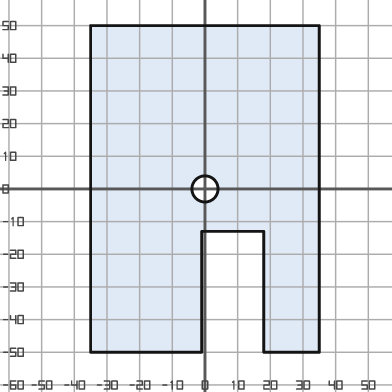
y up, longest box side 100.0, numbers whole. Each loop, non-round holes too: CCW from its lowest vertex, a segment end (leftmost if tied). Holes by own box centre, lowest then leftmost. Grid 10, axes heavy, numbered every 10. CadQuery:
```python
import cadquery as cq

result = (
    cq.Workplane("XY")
    .moveTo(-35.0, -50.0)
    .lineTo(-1.0, -50.0)
    .lineTo(-1.0, -13.0)
    .lineTo(18.0, -13.0)
    .lineTo(18.0, -50.0)
    .lineTo(35.0, -50.0)
    .lineTo(35.0, 50.0)
    .lineTo(-35.0, 50.0)
    .close()
    .moveTo(0.0, 0.0)
    .circle(4.0)
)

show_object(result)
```